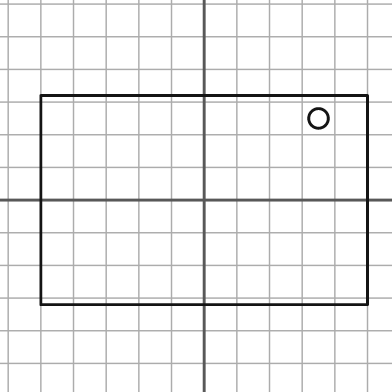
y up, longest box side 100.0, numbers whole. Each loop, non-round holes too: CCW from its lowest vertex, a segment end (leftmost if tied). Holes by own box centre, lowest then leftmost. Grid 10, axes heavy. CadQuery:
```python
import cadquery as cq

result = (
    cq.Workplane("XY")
    .moveTo(-50.0, -32.0)
    .lineTo(50.0, -32.0)
    .lineTo(50.0, 32.0)
    .lineTo(-50.0, 32.0)
    .close()
    .moveTo(35.0, 25.0)
    .circle(3.0)
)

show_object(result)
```